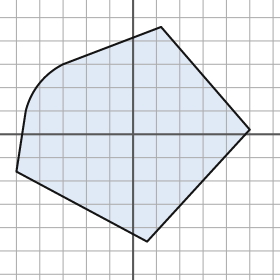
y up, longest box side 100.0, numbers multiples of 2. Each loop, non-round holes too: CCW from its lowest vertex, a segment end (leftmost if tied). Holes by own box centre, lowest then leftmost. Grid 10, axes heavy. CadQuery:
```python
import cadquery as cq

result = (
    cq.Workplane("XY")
    .moveTo(6.0, -46.0)
    .lineTo(50.0, 2.0)
    .lineTo(12.0, 46.0)
    .lineTo(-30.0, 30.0)
    .threePointArc((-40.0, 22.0), (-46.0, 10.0))
    .lineTo(-50.0, -16.0)
    .close()
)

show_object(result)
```